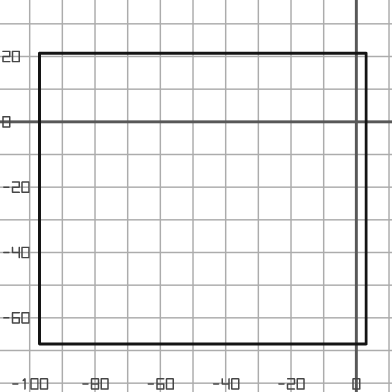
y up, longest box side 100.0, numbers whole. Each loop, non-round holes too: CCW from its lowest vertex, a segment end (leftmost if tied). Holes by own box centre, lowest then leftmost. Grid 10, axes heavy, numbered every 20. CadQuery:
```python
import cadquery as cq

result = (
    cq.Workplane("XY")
    .moveTo(-97.0, -68.0)
    .lineTo(3.0, -68.0)
    .lineTo(3.0, 21.0)
    .lineTo(-97.0, 21.0)
    .close()
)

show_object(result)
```